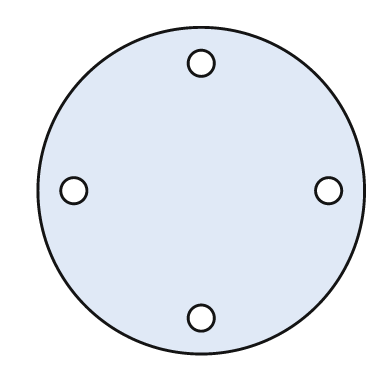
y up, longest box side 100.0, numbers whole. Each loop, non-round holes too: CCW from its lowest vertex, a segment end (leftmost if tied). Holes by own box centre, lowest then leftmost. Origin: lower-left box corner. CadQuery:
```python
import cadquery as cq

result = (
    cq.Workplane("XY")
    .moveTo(50.0, 50.0)
    .circle(50.0)
    .moveTo(50.0, 11.0)
    .circle(4.0)
    .moveTo(11.0, 50.0)
    .circle(4.0)
    .moveTo(89.0, 50.0)
    .circle(4.0)
    .moveTo(50.0, 89.0)
    .circle(4.0)
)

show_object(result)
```